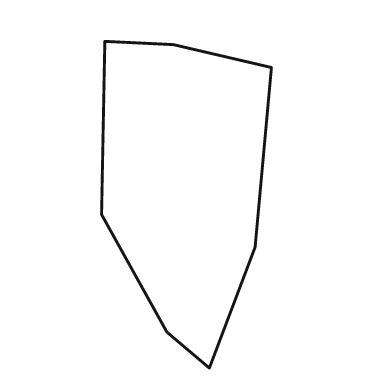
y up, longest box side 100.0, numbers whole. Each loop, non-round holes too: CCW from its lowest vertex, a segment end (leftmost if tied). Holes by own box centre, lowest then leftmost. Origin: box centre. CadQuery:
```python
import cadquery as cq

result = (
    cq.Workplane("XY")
    .moveTo(7.0, -50.0)
    .lineTo(21.0, -13.0)
    .lineTo(26.0, 42.0)
    .lineTo(-4.0, 49.0)
    .lineTo(-25.0, 50.0)
    .lineTo(-26.0, -3.0)
    .lineTo(-6.0, -39.0)
    .close()
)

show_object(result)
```